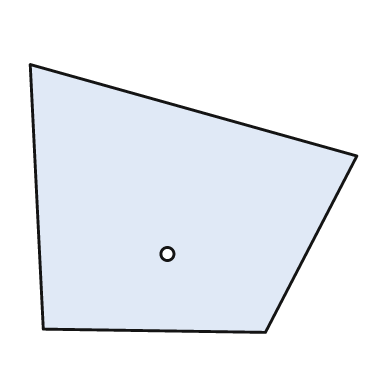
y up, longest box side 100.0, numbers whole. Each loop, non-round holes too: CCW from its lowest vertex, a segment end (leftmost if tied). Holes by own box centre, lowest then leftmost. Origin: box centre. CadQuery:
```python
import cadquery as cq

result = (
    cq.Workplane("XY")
    .moveTo(22.0, -41.0)
    .lineTo(50.0, 13.0)
    .lineTo(-50.0, 41.0)
    .lineTo(-46.0, -40.0)
    .close()
    .moveTo(-8.0, -17.0)
    .circle(2.0)
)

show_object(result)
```